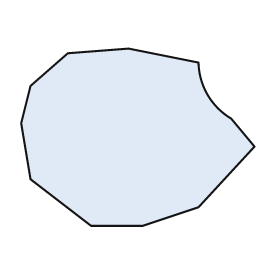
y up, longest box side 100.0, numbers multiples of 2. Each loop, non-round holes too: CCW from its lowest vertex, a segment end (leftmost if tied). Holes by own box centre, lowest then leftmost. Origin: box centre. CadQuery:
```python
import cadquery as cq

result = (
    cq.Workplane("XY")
    .moveTo(-20.0, -38.0)
    .lineTo(2.0, -38.0)
    .lineTo(26.0, -30.0)
    .lineTo(50.0, -4.0)
    .lineTo(40.0, 8.0)
    .threePointArc((30.0, 18.0), (26.0, 32.0))
    .lineTo(-4.0, 38.0)
    .lineTo(-30.0, 36.0)
    .lineTo(-46.0, 22.0)
    .lineTo(-50.0, 6.0)
    .lineTo(-46.0, -18.0)
    .close()
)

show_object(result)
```